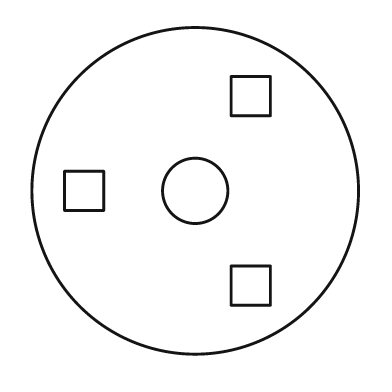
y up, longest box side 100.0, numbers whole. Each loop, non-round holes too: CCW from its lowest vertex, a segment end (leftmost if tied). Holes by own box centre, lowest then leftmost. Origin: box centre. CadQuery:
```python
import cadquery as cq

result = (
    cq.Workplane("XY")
    .moveTo(0.0, 0.0)
    .circle(50.0)
    .moveTo(11.0, -35.0)
    .lineTo(23.0, -35.0)
    .lineTo(23.0, -23.0)
    .lineTo(11.0, -23.0)
    .close()
    .moveTo(-40.0, -6.0)
    .lineTo(-28.0, -6.0)
    .lineTo(-28.0, 6.0)
    .lineTo(-40.0, 6.0)
    .close()
    .moveTo(0.0, 0.0)
    .circle(10.0)
    .moveTo(11.0, 23.0)
    .lineTo(23.0, 23.0)
    .lineTo(23.0, 35.0)
    .lineTo(11.0, 35.0)
    .close()
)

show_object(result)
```